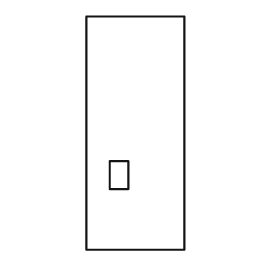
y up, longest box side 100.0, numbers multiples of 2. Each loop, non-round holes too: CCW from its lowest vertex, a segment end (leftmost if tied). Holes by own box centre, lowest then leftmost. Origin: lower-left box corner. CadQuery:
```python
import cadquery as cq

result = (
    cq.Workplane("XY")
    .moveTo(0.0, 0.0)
    .lineTo(42.0, 0.0)
    .lineTo(42.0, 100.0)
    .lineTo(0.0, 100.0)
    .close()
    .moveTo(10.0, 26.0)
    .lineTo(18.0, 26.0)
    .lineTo(18.0, 38.0)
    .lineTo(10.0, 38.0)
    .close()
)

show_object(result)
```